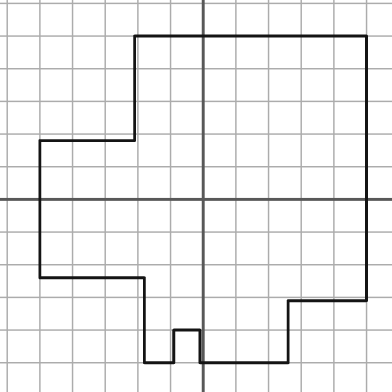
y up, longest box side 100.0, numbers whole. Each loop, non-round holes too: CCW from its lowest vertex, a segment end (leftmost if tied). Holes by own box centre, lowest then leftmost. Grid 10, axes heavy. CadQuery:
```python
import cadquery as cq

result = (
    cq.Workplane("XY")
    .moveTo(-18.0, -50.0)
    .lineTo(-9.0, -50.0)
    .lineTo(-9.0, -40.0)
    .lineTo(-1.0, -40.0)
    .lineTo(-1.0, -50.0)
    .lineTo(26.0, -50.0)
    .lineTo(26.0, -31.0)
    .lineTo(50.0, -31.0)
    .lineTo(50.0, 50.0)
    .lineTo(-21.0, 50.0)
    .lineTo(-21.0, 18.0)
    .lineTo(-50.0, 18.0)
    .lineTo(-50.0, -24.0)
    .lineTo(-18.0, -24.0)
    .close()
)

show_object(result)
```